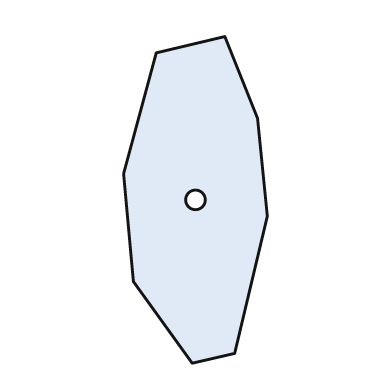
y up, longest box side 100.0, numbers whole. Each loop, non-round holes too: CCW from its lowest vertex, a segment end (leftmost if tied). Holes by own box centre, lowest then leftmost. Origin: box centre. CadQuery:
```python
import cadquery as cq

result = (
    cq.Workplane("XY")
    .moveTo(-1.0, -50.0)
    .lineTo(12.0, -47.0)
    .lineTo(22.0, -5.0)
    .lineTo(19.0, 25.0)
    .lineTo(9.0, 50.0)
    .lineTo(-12.0, 45.0)
    .lineTo(-22.0, 8.0)
    .lineTo(-19.0, -25.0)
    .close()
    .moveTo(0.0, 0.0)
    .circle(3.0)
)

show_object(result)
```